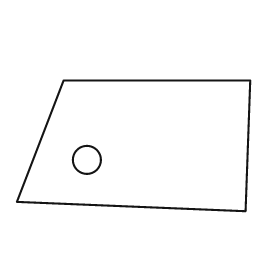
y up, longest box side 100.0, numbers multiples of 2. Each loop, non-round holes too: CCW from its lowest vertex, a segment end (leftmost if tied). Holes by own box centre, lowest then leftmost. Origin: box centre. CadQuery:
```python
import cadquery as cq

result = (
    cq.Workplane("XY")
    .moveTo(48.0, -28.0)
    .lineTo(50.0, 28.0)
    .lineTo(-30.0, 28.0)
    .lineTo(-50.0, -24.0)
    .close()
    .moveTo(-20.0, -6.0)
    .circle(6.0)
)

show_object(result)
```